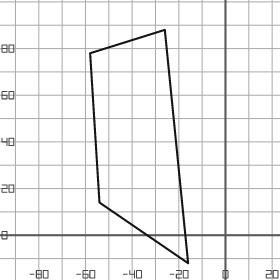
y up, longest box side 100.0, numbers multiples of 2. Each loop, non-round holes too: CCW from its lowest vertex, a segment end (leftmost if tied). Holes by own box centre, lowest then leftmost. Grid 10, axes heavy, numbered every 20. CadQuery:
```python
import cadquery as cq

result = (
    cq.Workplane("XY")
    .moveTo(-16.0, -12.0)
    .lineTo(-26.0, 88.0)
    .lineTo(-58.0, 78.0)
    .lineTo(-54.0, 14.0)
    .close()
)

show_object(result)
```